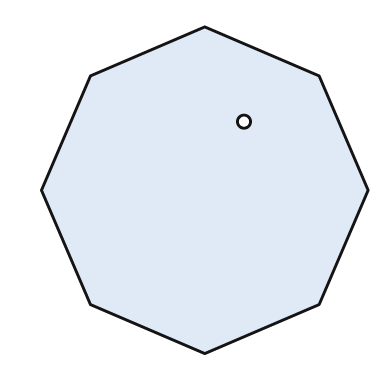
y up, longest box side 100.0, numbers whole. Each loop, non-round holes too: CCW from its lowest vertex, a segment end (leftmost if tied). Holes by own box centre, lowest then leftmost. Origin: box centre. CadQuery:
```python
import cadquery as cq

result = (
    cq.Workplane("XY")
    .moveTo(0.0, -50.0)
    .lineTo(35.0, -35.0)
    .lineTo(50.0, 0.0)
    .lineTo(35.0, 35.0)
    .lineTo(0.0, 50.0)
    .lineTo(-35.0, 35.0)
    .lineTo(-50.0, 0.0)
    .lineTo(-35.0, -35.0)
    .close()
    .moveTo(12.0, 21.0)
    .circle(2.0)
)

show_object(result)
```